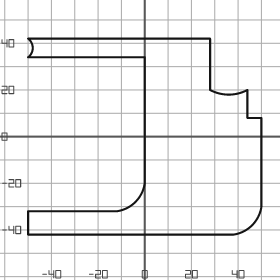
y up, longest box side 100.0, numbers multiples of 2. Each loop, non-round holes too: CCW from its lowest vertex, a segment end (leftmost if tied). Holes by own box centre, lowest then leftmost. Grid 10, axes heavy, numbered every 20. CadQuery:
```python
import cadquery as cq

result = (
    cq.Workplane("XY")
    .moveTo(-50.0, -42.0)
    .lineTo(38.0, -42.0)
    .threePointArc((46.0, -38.0), (50.0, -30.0))
    .lineTo(50.0, 8.0)
    .lineTo(44.0, 8.0)
    .lineTo(44.0, 20.0)
    .threePointArc((36.0, 18.0), (28.0, 20.0))
    .lineTo(28.0, 42.0)
    .lineTo(-50.0, 42.0)
    .threePointArc((-48.0, 38.0), (-50.0, 34.0))
    .lineTo(0.0, 34.0)
    .lineTo(0.0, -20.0)
    .threePointArc((-4.0, -28.0), (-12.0, -32.0))
    .lineTo(-50.0, -32.0)
    .close()
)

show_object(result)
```